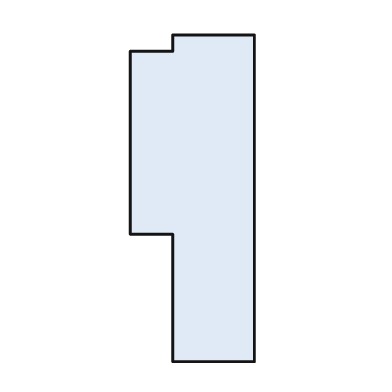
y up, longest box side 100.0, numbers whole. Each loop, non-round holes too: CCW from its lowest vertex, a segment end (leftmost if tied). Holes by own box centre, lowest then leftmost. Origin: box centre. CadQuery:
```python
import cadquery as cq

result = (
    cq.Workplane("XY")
    .moveTo(-6.0, -50.0)
    .lineTo(19.0, -50.0)
    .lineTo(19.0, 50.0)
    .lineTo(-6.0, 50.0)
    .lineTo(-6.0, 45.0)
    .lineTo(-19.0, 45.0)
    .lineTo(-19.0, -11.0)
    .lineTo(-6.0, -11.0)
    .close()
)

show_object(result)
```